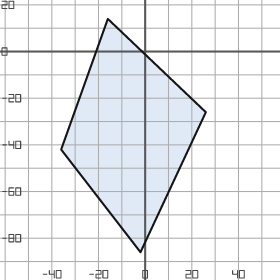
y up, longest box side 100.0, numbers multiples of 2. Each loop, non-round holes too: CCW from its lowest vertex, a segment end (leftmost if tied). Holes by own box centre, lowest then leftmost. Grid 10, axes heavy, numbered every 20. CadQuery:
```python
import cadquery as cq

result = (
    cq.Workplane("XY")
    .moveTo(-2.0, -86.0)
    .lineTo(26.0, -26.0)
    .lineTo(-16.0, 14.0)
    .lineTo(-36.0, -42.0)
    .close()
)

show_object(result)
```